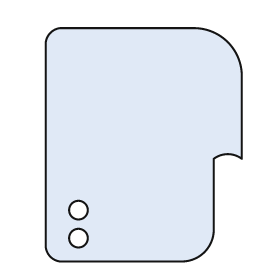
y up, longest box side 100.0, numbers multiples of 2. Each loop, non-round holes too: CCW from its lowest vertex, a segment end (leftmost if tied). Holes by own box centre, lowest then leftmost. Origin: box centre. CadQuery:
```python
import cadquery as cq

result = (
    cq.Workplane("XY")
    .moveTo(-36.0, -50.0)
    .lineTo(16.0, -50.0)
    .threePointArc((26.0, -46.0), (30.0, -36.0))
    .lineTo(30.0, -6.0)
    .threePointArc((36.0, -4.0), (42.0, -6.0))
    .lineTo(42.0, 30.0)
    .threePointArc((36.0, 44.0), (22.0, 50.0))
    .lineTo(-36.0, 50.0)
    .threePointArc((-40.0, 48.0), (-42.0, 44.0))
    .lineTo(-42.0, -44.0)
    .threePointArc((-40.0, -48.0), (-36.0, -50.0))
    .close()
    .moveTo(-28.0, -40.0)
    .circle(4.0)
    .moveTo(-28.0, -28.0)
    .circle(4.0)
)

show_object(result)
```